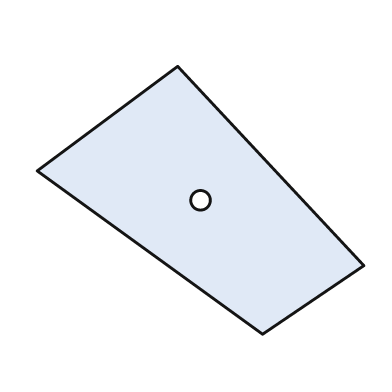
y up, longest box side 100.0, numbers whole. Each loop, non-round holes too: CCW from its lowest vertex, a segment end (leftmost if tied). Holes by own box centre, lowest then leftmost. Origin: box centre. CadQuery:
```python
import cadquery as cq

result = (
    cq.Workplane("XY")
    .moveTo(19.0, -41.0)
    .lineTo(50.0, -20.0)
    .lineTo(-7.0, 41.0)
    .lineTo(-50.0, 9.0)
    .close()
    .moveTo(0.0, 0.0)
    .circle(3.0)
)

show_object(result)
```